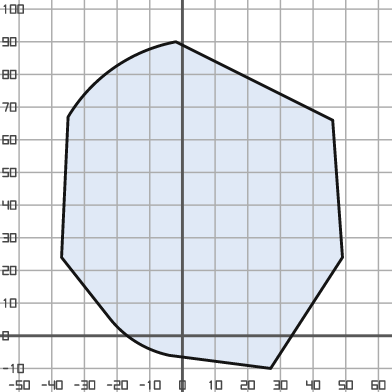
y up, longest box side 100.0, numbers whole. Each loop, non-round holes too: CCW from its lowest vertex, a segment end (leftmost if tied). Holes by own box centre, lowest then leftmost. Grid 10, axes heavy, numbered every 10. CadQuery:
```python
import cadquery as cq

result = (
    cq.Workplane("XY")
    .moveTo(27.0, -10.0)
    .lineTo(49.0, 24.0)
    .lineTo(46.0, 66.0)
    .lineTo(-2.0, 90.0)
    .threePointArc((-21.0, 82.0), (-35.0, 67.0))
    .lineTo(-37.0, 24.0)
    .lineTo(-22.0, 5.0)
    .threePointArc((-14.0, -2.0), (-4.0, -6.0))
    .close()
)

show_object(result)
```